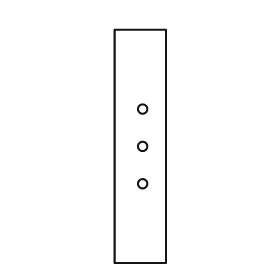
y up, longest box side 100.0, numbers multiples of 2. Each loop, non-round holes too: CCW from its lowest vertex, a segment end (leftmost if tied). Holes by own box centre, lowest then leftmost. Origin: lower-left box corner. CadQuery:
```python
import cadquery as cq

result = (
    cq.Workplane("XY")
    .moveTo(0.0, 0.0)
    .lineTo(22.0, 0.0)
    .lineTo(22.0, 100.0)
    .lineTo(0.0, 100.0)
    .close()
    .moveTo(12.0, 34.0)
    .circle(2.0)
    .moveTo(12.0, 50.0)
    .circle(2.0)
    .moveTo(12.0, 66.0)
    .circle(2.0)
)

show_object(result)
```